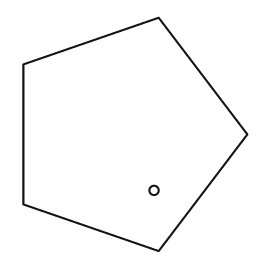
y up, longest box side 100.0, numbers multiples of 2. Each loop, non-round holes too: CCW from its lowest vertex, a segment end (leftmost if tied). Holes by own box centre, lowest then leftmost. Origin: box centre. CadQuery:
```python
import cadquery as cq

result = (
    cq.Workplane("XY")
    .moveTo(10.0, -50.0)
    .lineTo(48.0, 0.0)
    .lineTo(10.0, 50.0)
    .lineTo(-48.0, 30.0)
    .lineTo(-48.0, -30.0)
    .close()
    .moveTo(8.0, -24.0)
    .circle(2.0)
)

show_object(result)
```